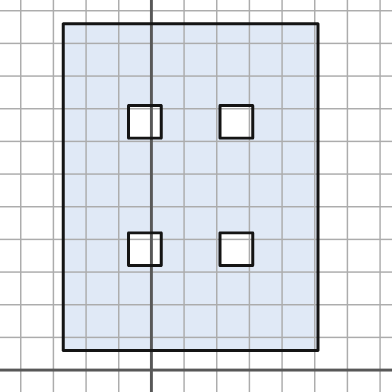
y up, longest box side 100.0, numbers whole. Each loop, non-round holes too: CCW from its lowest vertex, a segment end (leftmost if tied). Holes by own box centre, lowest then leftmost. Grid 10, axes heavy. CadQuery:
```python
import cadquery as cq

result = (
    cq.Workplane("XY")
    .moveTo(-27.0, 6.0)
    .lineTo(51.0, 6.0)
    .lineTo(51.0, 106.0)
    .lineTo(-27.0, 106.0)
    .close()
    .moveTo(-7.0, 32.0)
    .lineTo(3.0, 32.0)
    .lineTo(3.0, 42.0)
    .lineTo(-7.0, 42.0)
    .close()
    .moveTo(21.0, 32.0)
    .lineTo(31.0, 32.0)
    .lineTo(31.0, 42.0)
    .lineTo(21.0, 42.0)
    .close()
    .moveTo(-7.0, 71.0)
    .lineTo(3.0, 71.0)
    .lineTo(3.0, 81.0)
    .lineTo(-7.0, 81.0)
    .close()
    .moveTo(21.0, 71.0)
    .lineTo(31.0, 71.0)
    .lineTo(31.0, 81.0)
    .lineTo(21.0, 81.0)
    .close()
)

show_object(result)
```